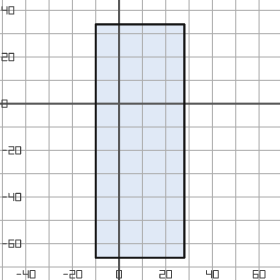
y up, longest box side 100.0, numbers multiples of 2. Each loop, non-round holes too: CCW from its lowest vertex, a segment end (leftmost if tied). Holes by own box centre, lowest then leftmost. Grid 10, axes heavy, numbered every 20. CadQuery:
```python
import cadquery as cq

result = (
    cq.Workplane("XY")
    .moveTo(-10.0, -66.0)
    .lineTo(28.0, -66.0)
    .lineTo(28.0, 34.0)
    .lineTo(-10.0, 34.0)
    .close()
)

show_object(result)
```